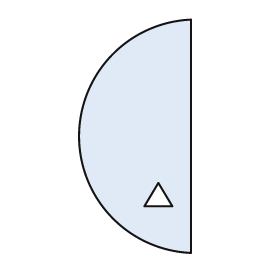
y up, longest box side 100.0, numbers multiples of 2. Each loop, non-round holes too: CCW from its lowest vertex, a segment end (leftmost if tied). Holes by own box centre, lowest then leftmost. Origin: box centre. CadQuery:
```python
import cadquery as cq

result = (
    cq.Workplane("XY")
    .moveTo(24.0, -50.0)
    .lineTo(24.0, 50.0)
    .threePointArc((-24.0, 0.0), (24.0, -50.0))
    .close()
    .moveTo(4.0, -30.0)
    .lineTo(16.0, -30.0)
    .lineTo(10.0, -20.0)
    .close()
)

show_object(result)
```